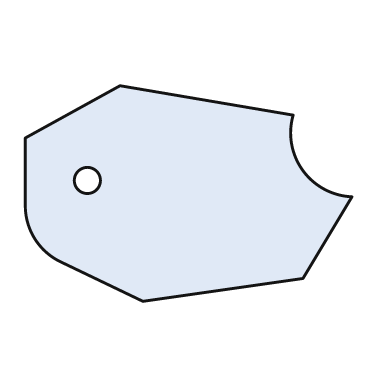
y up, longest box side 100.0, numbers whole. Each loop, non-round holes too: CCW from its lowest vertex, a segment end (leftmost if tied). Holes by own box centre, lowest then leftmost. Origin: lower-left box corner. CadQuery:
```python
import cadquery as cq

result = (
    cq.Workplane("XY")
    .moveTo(36.0, 0.0)
    .lineTo(85.0, 7.0)
    .lineTo(100.0, 32.0)
    .threePointArc((85.0, 40.0), (82.0, 57.0))
    .lineTo(29.0, 66.0)
    .lineTo(0.0, 50.0)
    .lineTo(0.0, 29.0)
    .threePointArc((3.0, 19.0), (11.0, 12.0))
    .close()
    .moveTo(19.0, 37.0)
    .circle(4.0)
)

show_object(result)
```